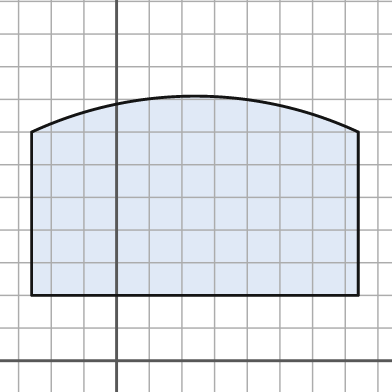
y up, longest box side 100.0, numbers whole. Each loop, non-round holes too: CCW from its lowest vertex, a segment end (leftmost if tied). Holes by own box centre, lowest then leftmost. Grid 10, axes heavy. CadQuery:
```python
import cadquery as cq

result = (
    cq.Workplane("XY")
    .moveTo(-26.0, 20.0)
    .lineTo(74.0, 20.0)
    .lineTo(74.0, 70.0)
    .threePointArc((24.0, 81.0), (-26.0, 70.0))
    .close()
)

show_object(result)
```